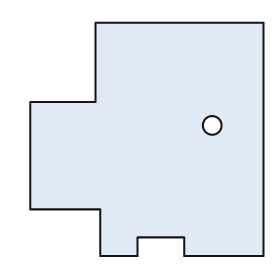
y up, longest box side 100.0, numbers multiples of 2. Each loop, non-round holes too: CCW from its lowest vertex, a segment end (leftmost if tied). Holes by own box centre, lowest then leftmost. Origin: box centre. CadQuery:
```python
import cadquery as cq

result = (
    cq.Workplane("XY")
    .moveTo(-20.0, -50.0)
    .lineTo(-4.0, -50.0)
    .lineTo(-4.0, -42.0)
    .lineTo(16.0, -42.0)
    .lineTo(16.0, -50.0)
    .lineTo(50.0, -50.0)
    .lineTo(50.0, 50.0)
    .lineTo(-22.0, 50.0)
    .lineTo(-22.0, 16.0)
    .lineTo(-50.0, 16.0)
    .lineTo(-50.0, -30.0)
    .lineTo(-20.0, -30.0)
    .close()
    .moveTo(28.0, 6.0)
    .circle(4.0)
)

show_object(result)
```